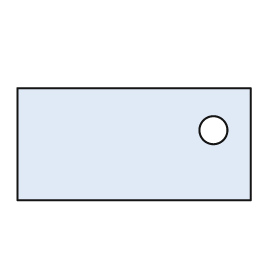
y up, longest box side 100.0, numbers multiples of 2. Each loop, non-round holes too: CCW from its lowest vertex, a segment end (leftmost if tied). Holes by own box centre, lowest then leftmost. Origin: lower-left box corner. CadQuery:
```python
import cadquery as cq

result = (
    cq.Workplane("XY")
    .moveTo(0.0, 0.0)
    .lineTo(100.0, 0.0)
    .lineTo(100.0, 48.0)
    .lineTo(0.0, 48.0)
    .close()
    .moveTo(84.0, 30.0)
    .circle(6.0)
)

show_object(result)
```